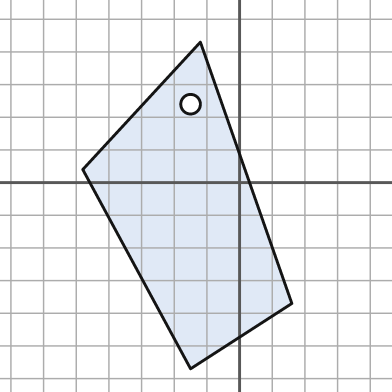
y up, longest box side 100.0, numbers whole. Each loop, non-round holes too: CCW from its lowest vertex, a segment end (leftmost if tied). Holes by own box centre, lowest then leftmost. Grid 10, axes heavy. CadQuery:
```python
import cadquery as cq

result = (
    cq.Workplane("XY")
    .moveTo(-15.0, -57.0)
    .lineTo(16.0, -37.0)
    .lineTo(-12.0, 43.0)
    .lineTo(-48.0, 4.0)
    .close()
    .moveTo(-15.0, 24.0)
    .circle(3.0)
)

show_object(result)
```